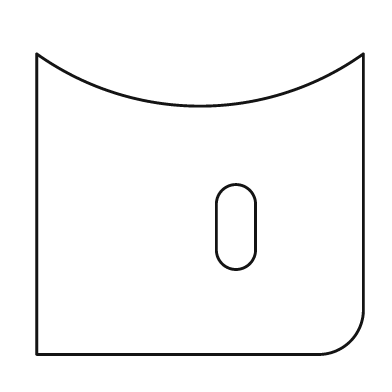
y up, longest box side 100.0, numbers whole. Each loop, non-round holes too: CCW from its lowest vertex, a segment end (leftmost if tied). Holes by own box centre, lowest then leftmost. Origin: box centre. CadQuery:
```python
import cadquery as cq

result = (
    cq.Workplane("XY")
    .moveTo(-50.0, -46.0)
    .lineTo(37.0, -46.0)
    .threePointArc((46.0, -42.0), (50.0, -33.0))
    .lineTo(50.0, 46.0)
    .threePointArc((0.0, 30.0), (-50.0, 46.0))
    .close()
    .moveTo(5.0, -14.0)
    .threePointArc((11.0, -20.0), (17.0, -14.0))
    .lineTo(17.0, 0.0)
    .threePointArc((11.0, 6.0), (5.0, 0.0))
    .close()
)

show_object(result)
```